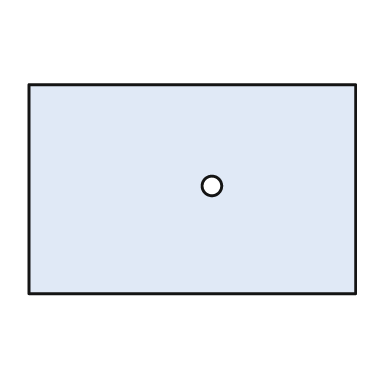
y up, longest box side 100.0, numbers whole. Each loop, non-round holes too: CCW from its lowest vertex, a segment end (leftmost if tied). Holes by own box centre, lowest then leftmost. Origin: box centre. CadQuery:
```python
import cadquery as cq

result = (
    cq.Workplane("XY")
    .moveTo(-50.0, -32.0)
    .lineTo(50.0, -32.0)
    .lineTo(50.0, 32.0)
    .lineTo(-50.0, 32.0)
    .close()
    .moveTo(6.0, 1.0)
    .circle(3.0)
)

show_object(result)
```